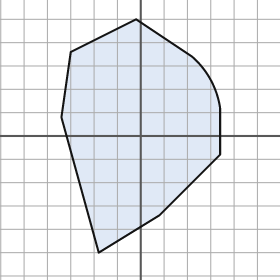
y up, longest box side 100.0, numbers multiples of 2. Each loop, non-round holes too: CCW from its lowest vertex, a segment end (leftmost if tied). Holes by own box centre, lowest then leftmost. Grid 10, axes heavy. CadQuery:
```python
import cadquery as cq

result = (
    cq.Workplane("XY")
    .moveTo(-18.0, -50.0)
    .lineTo(8.0, -34.0)
    .lineTo(34.0, -8.0)
    .lineTo(34.0, 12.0)
    .threePointArc((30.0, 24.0), (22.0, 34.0))
    .lineTo(-2.0, 50.0)
    .lineTo(-30.0, 36.0)
    .lineTo(-34.0, 8.0)
    .close()
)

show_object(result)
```